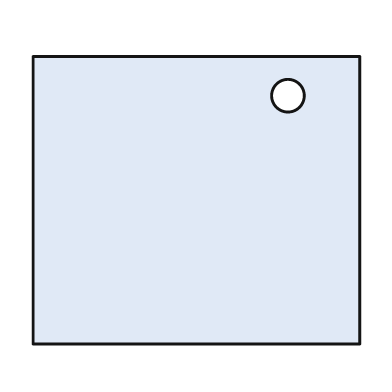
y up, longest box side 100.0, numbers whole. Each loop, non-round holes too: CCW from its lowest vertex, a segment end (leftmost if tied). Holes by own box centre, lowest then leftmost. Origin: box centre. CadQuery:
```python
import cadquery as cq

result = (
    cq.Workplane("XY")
    .moveTo(-50.0, -44.0)
    .lineTo(50.0, -44.0)
    .lineTo(50.0, 44.0)
    .lineTo(-50.0, 44.0)
    .close()
    .moveTo(28.0, 32.0)
    .circle(5.0)
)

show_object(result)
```